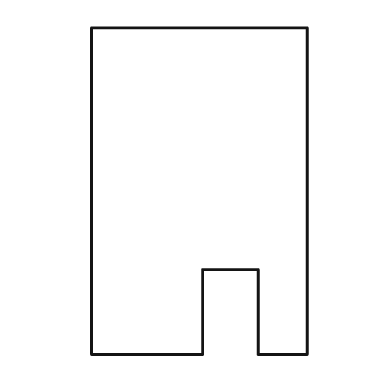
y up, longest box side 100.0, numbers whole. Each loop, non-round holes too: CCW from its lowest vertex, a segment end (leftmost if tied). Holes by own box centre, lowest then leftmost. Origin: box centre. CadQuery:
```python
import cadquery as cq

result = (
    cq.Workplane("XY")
    .moveTo(-33.0, -50.0)
    .lineTo(1.0, -50.0)
    .lineTo(1.0, -24.0)
    .lineTo(18.0, -24.0)
    .lineTo(18.0, -50.0)
    .lineTo(33.0, -50.0)
    .lineTo(33.0, 50.0)
    .lineTo(-33.0, 50.0)
    .close()
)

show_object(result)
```